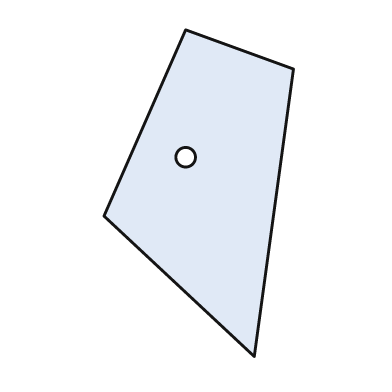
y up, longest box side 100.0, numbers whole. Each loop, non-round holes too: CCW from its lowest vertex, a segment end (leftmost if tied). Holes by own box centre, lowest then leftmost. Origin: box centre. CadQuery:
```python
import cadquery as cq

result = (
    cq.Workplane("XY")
    .moveTo(17.0, -50.0)
    .lineTo(29.0, 38.0)
    .lineTo(-4.0, 50.0)
    .lineTo(-29.0, -7.0)
    .close()
    .moveTo(-4.0, 11.0)
    .circle(3.0)
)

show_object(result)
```